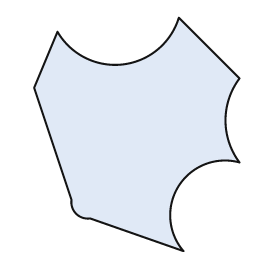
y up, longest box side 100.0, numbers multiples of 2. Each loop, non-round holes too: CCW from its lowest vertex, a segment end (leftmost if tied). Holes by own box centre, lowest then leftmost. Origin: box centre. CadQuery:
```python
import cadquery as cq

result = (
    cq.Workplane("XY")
    .moveTo(20.0, -50.0)
    .threePointArc((18.0, -22.0), (44.0, -12.0))
    .threePointArc((38.0, 6.0), (44.0, 24.0))
    .lineTo(18.0, 50.0)
    .threePointArc((-6.0, 30.0), (-34.0, 44.0))
    .lineTo(-44.0, 20.0)
    .lineTo(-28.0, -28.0)
    .threePointArc((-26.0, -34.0), (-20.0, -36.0))
    .close()
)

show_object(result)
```